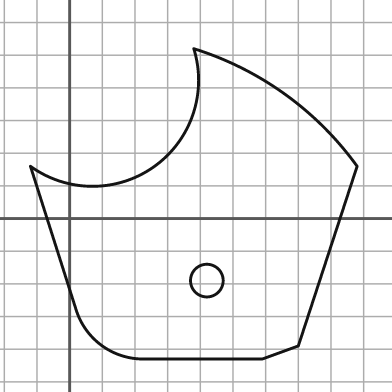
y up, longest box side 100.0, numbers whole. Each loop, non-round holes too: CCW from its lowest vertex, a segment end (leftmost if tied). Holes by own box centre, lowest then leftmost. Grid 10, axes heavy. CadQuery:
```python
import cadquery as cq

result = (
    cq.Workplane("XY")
    .moveTo(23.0, -43.0)
    .lineTo(59.0, -43.0)
    .lineTo(70.0, -39.0)
    .lineTo(88.0, 16.0)
    .threePointArc((66.0, 38.0), (38.0, 52.0))
    .threePointArc((26.0, 16.0), (-12.0, 16.0))
    .lineTo(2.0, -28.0)
    .threePointArc((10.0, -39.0), (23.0, -43.0))
    .close()
    .moveTo(42.0, -19.0)
    .circle(5.0)
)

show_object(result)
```